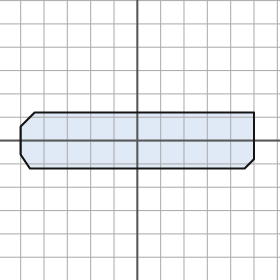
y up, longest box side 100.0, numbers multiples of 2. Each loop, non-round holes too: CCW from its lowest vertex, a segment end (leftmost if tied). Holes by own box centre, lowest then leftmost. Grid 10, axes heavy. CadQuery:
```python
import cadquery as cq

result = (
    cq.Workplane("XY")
    .moveTo(-46.0, -12.0)
    .lineTo(46.0, -12.0)
    .lineTo(50.0, -8.0)
    .lineTo(50.0, 12.0)
    .lineTo(-44.0, 12.0)
    .lineTo(-50.0, 6.0)
    .lineTo(-50.0, -6.0)
    .close()
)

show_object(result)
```